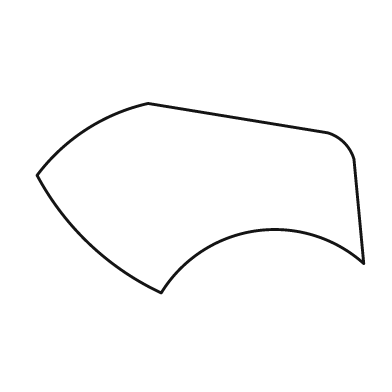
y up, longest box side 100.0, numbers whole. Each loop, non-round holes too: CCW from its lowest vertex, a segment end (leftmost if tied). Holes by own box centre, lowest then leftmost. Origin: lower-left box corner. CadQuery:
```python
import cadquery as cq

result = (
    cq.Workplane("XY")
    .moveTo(38.0, 0.0)
    .threePointArc((67.0, 19.0), (100.0, 9.0))
    .lineTo(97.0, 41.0)
    .threePointArc((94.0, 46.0), (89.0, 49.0))
    .lineTo(34.0, 58.0)
    .threePointArc((15.0, 50.0), (0.0, 36.0))
    .threePointArc((16.0, 15.0), (38.0, 0.0))
    .close()
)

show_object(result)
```